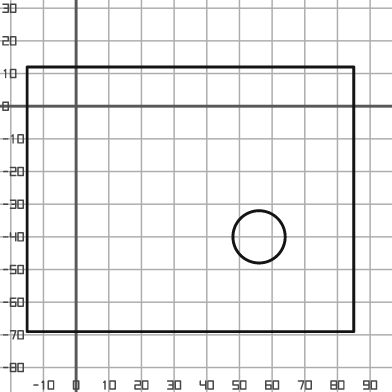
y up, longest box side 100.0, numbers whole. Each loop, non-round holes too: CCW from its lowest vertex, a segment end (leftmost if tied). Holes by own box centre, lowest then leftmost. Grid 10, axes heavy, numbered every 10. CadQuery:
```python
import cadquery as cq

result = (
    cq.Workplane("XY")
    .moveTo(-15.0, -69.0)
    .lineTo(85.0, -69.0)
    .lineTo(85.0, 12.0)
    .lineTo(-15.0, 12.0)
    .close()
    .moveTo(56.0, -40.0)
    .circle(8.0)
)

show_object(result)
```